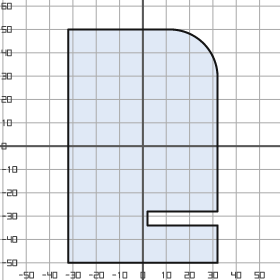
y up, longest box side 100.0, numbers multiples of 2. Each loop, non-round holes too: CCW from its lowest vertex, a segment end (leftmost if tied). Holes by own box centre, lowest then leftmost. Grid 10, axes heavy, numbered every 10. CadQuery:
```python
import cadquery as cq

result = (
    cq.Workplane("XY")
    .moveTo(-32.0, -50.0)
    .lineTo(32.0, -50.0)
    .lineTo(32.0, -34.0)
    .lineTo(2.0, -34.0)
    .lineTo(2.0, -28.0)
    .lineTo(32.0, -28.0)
    .lineTo(32.0, 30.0)
    .threePointArc((26.0, 44.0), (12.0, 50.0))
    .lineTo(-32.0, 50.0)
    .close()
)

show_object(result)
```